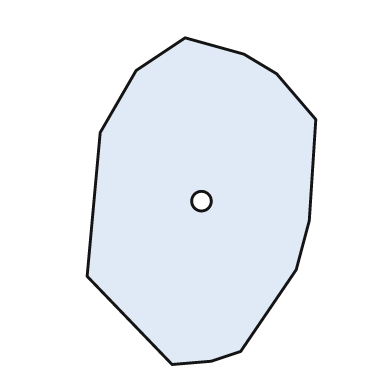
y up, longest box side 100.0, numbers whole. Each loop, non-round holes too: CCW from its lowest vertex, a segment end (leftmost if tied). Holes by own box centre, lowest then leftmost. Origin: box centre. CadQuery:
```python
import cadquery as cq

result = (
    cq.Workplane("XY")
    .moveTo(-9.0, -50.0)
    .lineTo(3.0, -49.0)
    .lineTo(12.0, -46.0)
    .lineTo(29.0, -21.0)
    .lineTo(33.0, -6.0)
    .lineTo(35.0, 25.0)
    .lineTo(23.0, 39.0)
    .lineTo(13.0, 45.0)
    .lineTo(-5.0, 50.0)
    .lineTo(-20.0, 40.0)
    .lineTo(-31.0, 21.0)
    .lineTo(-35.0, -23.0)
    .close()
    .moveTo(0.0, 0.0)
    .circle(3.0)
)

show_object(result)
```